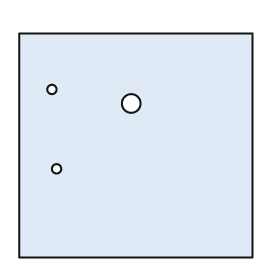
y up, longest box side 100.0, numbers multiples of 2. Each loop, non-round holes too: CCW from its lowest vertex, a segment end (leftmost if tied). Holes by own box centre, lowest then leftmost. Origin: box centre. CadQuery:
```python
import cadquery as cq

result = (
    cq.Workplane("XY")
    .moveTo(-50.0, -48.0)
    .lineTo(50.0, -48.0)
    .lineTo(50.0, 48.0)
    .lineTo(-50.0, 48.0)
    .close()
    .moveTo(-34.0, -10.0)
    .circle(2.0)
    .moveTo(-2.0, 18.0)
    .circle(4.0)
    .moveTo(-36.0, 24.0)
    .circle(2.0)
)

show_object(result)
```